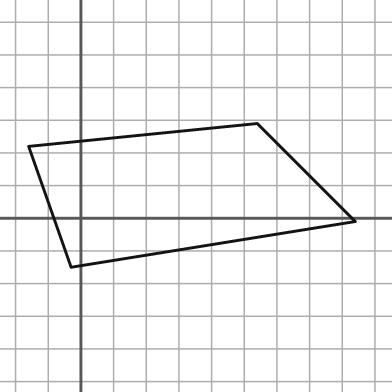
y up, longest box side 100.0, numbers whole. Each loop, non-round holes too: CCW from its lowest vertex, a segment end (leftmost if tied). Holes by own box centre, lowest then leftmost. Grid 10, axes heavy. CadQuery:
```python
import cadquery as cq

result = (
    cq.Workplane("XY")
    .moveTo(-3.0, -15.0)
    .lineTo(84.0, -1.0)
    .lineTo(54.0, 29.0)
    .lineTo(-16.0, 22.0)
    .close()
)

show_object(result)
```